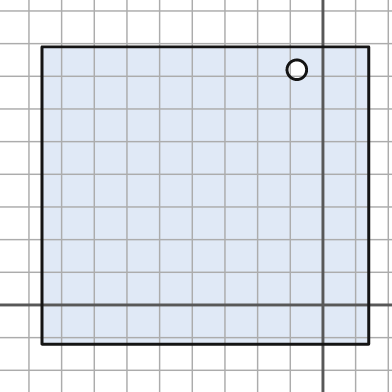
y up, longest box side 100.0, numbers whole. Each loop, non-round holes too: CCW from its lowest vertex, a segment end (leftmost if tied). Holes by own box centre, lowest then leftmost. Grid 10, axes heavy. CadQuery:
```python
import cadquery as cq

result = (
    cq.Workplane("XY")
    .moveTo(-86.0, -12.0)
    .lineTo(14.0, -12.0)
    .lineTo(14.0, 79.0)
    .lineTo(-86.0, 79.0)
    .close()
    .moveTo(-8.0, 72.0)
    .circle(3.0)
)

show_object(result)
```